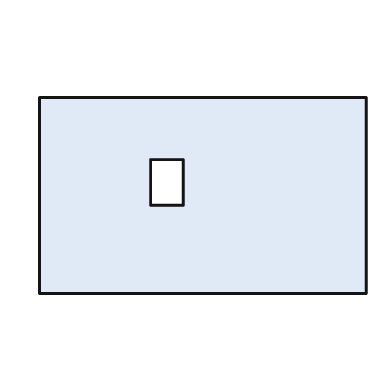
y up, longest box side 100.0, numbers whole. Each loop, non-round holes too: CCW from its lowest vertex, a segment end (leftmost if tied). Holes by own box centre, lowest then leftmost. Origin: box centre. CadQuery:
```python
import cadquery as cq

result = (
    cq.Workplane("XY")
    .moveTo(-50.0, -30.0)
    .lineTo(50.0, -30.0)
    .lineTo(50.0, 30.0)
    .lineTo(-50.0, 30.0)
    .close()
    .moveTo(-16.0, -3.0)
    .lineTo(-6.0, -3.0)
    .lineTo(-6.0, 11.0)
    .lineTo(-16.0, 11.0)
    .close()
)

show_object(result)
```